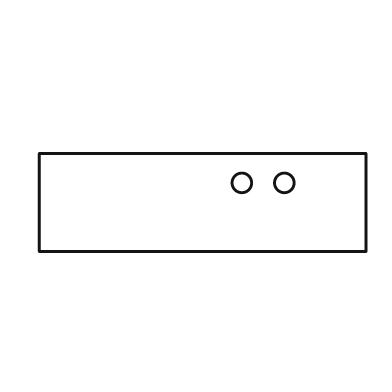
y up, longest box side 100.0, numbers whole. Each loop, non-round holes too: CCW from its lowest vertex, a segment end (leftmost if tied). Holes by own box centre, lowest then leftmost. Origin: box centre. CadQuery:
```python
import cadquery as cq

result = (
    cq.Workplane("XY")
    .moveTo(-50.0, -15.0)
    .lineTo(50.0, -15.0)
    .lineTo(50.0, 15.0)
    .lineTo(-50.0, 15.0)
    .close()
    .moveTo(12.0, 6.0)
    .circle(3.0)
    .moveTo(25.0, 6.0)
    .circle(3.0)
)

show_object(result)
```